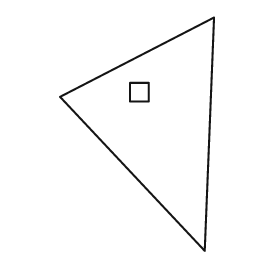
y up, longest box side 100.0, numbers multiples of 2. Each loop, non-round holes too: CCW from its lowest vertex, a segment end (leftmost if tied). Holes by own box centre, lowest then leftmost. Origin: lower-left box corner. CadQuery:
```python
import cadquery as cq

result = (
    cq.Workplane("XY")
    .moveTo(62.0, 0.0)
    .lineTo(66.0, 100.0)
    .lineTo(0.0, 66.0)
    .close()
    .moveTo(30.0, 64.0)
    .lineTo(38.0, 64.0)
    .lineTo(38.0, 72.0)
    .lineTo(30.0, 72.0)
    .close()
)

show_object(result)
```